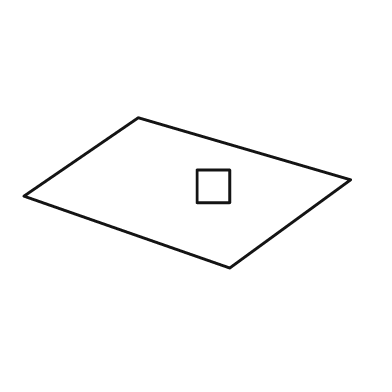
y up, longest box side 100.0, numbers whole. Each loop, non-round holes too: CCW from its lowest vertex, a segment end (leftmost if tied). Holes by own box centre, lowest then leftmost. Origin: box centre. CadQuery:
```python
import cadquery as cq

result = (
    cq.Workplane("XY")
    .moveTo(13.0, -23.0)
    .lineTo(50.0, 4.0)
    .lineTo(-15.0, 23.0)
    .lineTo(-50.0, -1.0)
    .close()
    .moveTo(3.0, -3.0)
    .lineTo(13.0, -3.0)
    .lineTo(13.0, 7.0)
    .lineTo(3.0, 7.0)
    .close()
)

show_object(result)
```